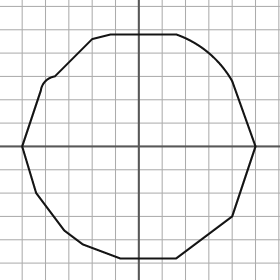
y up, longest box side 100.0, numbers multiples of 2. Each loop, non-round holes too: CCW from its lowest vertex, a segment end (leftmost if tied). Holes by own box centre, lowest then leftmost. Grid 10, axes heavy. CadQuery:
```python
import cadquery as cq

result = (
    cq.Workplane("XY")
    .moveTo(-8.0, -48.0)
    .lineTo(16.0, -48.0)
    .lineTo(40.0, -30.0)
    .lineTo(50.0, 0.0)
    .lineTo(40.0, 28.0)
    .threePointArc((30.0, 40.0), (16.0, 48.0))
    .lineTo(-12.0, 48.0)
    .lineTo(-20.0, 46.0)
    .lineTo(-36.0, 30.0)
    .threePointArc((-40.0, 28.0), (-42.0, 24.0))
    .lineTo(-50.0, 0.0)
    .lineTo(-44.0, -20.0)
    .lineTo(-32.0, -36.0)
    .lineTo(-24.0, -42.0)
    .close()
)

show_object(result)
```